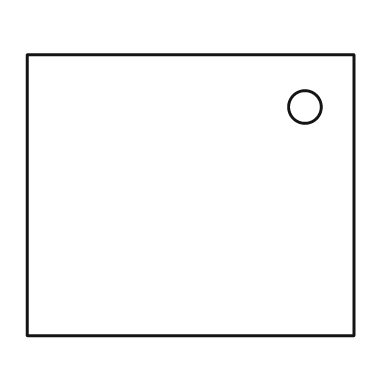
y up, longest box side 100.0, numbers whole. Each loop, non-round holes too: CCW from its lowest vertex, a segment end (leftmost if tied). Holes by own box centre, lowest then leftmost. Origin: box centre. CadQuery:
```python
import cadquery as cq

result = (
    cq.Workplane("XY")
    .moveTo(-50.0, -43.0)
    .lineTo(50.0, -43.0)
    .lineTo(50.0, 43.0)
    .lineTo(-50.0, 43.0)
    .close()
    .moveTo(35.0, 27.0)
    .circle(5.0)
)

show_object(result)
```